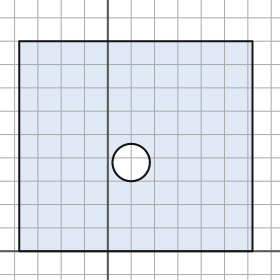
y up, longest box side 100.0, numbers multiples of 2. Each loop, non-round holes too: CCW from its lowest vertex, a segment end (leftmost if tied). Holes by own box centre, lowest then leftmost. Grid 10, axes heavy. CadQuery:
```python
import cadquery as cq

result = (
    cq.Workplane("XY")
    .moveTo(-38.0, 0.0)
    .lineTo(62.0, 0.0)
    .lineTo(62.0, 90.0)
    .lineTo(-38.0, 90.0)
    .close()
    .moveTo(10.0, 38.0)
    .circle(8.0)
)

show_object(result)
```